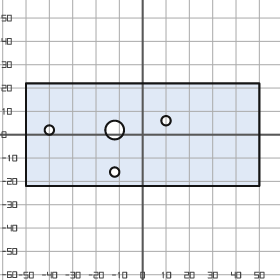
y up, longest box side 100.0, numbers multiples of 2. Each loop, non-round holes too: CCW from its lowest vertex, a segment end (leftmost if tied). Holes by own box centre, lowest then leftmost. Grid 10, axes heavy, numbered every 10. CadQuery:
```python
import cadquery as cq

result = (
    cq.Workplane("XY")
    .moveTo(-50.0, -22.0)
    .lineTo(50.0, -22.0)
    .lineTo(50.0, 22.0)
    .lineTo(-50.0, 22.0)
    .close()
    .moveTo(-12.0, -16.0)
    .circle(2.0)
    .moveTo(-40.0, 2.0)
    .circle(2.0)
    .moveTo(-12.0, 2.0)
    .circle(4.0)
    .moveTo(10.0, 6.0)
    .circle(2.0)
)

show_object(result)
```